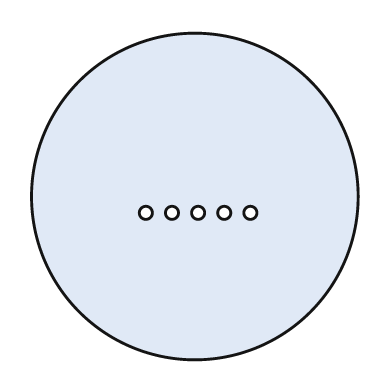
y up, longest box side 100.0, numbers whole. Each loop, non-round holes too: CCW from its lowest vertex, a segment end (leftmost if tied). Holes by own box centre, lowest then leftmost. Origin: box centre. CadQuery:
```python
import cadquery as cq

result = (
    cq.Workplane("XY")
    .moveTo(0.0, 0.0)
    .circle(50.0)
    .moveTo(-15.0, -5.0)
    .circle(2.0)
    .moveTo(-7.0, -5.0)
    .circle(2.0)
    .moveTo(1.0, -5.0)
    .circle(2.0)
    .moveTo(9.0, -5.0)
    .circle(2.0)
    .moveTo(17.0, -5.0)
    .circle(2.0)
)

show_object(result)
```